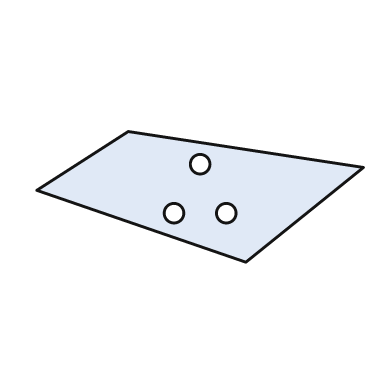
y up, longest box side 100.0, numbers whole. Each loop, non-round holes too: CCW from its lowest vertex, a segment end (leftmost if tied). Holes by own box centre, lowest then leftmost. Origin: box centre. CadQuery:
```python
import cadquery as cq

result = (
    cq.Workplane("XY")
    .moveTo(14.0, -20.0)
    .lineTo(50.0, 9.0)
    .lineTo(-22.0, 20.0)
    .lineTo(-50.0, 2.0)
    .close()
    .moveTo(-8.0, -5.0)
    .circle(3.0)
    .moveTo(8.0, -5.0)
    .circle(3.0)
    .moveTo(0.0, 10.0)
    .circle(3.0)
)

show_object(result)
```